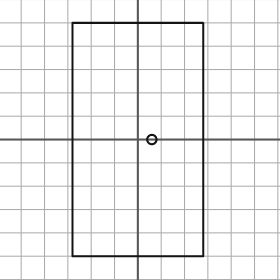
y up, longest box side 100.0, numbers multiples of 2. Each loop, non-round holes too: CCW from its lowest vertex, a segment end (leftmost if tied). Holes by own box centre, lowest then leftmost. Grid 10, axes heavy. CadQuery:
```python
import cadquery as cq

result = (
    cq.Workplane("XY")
    .moveTo(-28.0, -50.0)
    .lineTo(28.0, -50.0)
    .lineTo(28.0, 50.0)
    .lineTo(-28.0, 50.0)
    .close()
    .moveTo(6.0, 0.0)
    .circle(2.0)
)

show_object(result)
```